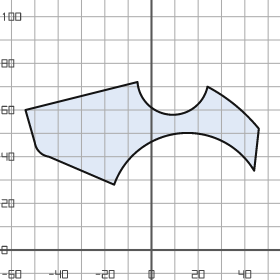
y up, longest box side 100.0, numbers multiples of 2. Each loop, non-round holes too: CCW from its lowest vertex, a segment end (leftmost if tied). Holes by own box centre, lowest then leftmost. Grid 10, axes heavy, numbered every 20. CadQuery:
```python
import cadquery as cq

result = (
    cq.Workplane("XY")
    .moveTo(-16.0, 28.0)
    .threePointArc((12.0, 50.0), (44.0, 34.0))
    .lineTo(46.0, 52.0)
    .threePointArc((36.0, 62.0), (24.0, 70.0))
    .threePointArc((8.0, 58.0), (-6.0, 72.0))
    .lineTo(-54.0, 60.0)
    .lineTo(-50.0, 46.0)
    .threePointArc((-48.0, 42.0), (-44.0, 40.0))
    .close()
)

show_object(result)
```